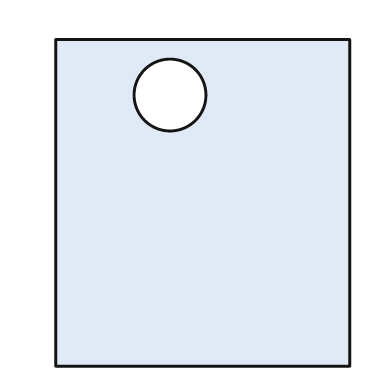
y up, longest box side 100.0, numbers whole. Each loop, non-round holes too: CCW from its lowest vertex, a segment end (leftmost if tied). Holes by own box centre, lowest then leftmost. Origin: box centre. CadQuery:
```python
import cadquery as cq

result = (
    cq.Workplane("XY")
    .moveTo(-45.0, -50.0)
    .lineTo(45.0, -50.0)
    .lineTo(45.0, 50.0)
    .lineTo(-45.0, 50.0)
    .close()
    .moveTo(-10.0, 33.0)
    .circle(11.0)
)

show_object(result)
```